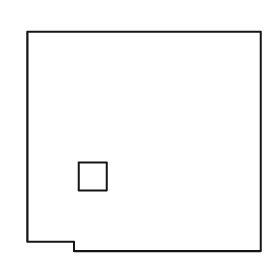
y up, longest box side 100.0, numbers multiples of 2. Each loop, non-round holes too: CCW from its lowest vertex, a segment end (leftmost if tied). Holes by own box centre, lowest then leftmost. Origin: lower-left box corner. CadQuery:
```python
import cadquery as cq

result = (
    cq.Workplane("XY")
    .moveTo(20.0, 0.0)
    .lineTo(100.0, 0.0)
    .lineTo(100.0, 94.0)
    .lineTo(0.0, 94.0)
    .lineTo(0.0, 4.0)
    .lineTo(20.0, 4.0)
    .close()
    .moveTo(22.0, 26.0)
    .lineTo(34.0, 26.0)
    .lineTo(34.0, 38.0)
    .lineTo(22.0, 38.0)
    .close()
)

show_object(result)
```